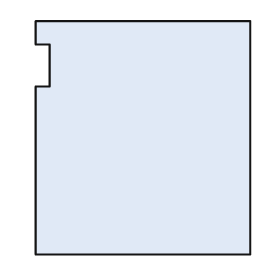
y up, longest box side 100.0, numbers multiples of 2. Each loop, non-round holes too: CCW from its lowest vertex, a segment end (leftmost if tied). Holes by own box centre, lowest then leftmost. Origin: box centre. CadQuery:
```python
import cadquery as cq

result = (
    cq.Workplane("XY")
    .moveTo(-46.0, -50.0)
    .lineTo(46.0, -50.0)
    .lineTo(46.0, 50.0)
    .lineTo(-46.0, 50.0)
    .lineTo(-46.0, 40.0)
    .lineTo(-40.0, 40.0)
    .lineTo(-40.0, 22.0)
    .lineTo(-46.0, 22.0)
    .close()
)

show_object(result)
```